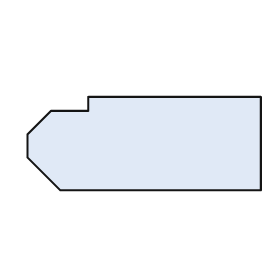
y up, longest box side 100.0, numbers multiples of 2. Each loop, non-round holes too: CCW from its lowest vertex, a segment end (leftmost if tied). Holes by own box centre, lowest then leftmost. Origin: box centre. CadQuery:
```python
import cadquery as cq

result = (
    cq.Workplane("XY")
    .moveTo(-36.0, -20.0)
    .lineTo(50.0, -20.0)
    .lineTo(50.0, 20.0)
    .lineTo(-24.0, 20.0)
    .lineTo(-24.0, 14.0)
    .lineTo(-40.0, 14.0)
    .lineTo(-50.0, 4.0)
    .lineTo(-50.0, -6.0)
    .close()
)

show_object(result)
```